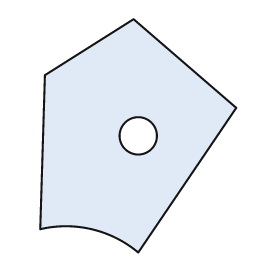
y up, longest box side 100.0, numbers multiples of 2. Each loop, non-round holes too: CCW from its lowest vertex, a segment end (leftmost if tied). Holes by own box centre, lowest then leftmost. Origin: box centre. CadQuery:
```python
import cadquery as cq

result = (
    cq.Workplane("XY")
    .moveTo(0.0, -50.0)
    .lineTo(42.0, 12.0)
    .lineTo(-2.0, 50.0)
    .lineTo(-40.0, 26.0)
    .lineTo(-42.0, -40.0)
    .threePointArc((-20.0, -40.0), (0.0, -50.0))
    .close()
    .moveTo(0.0, 0.0)
    .circle(8.0)
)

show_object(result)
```